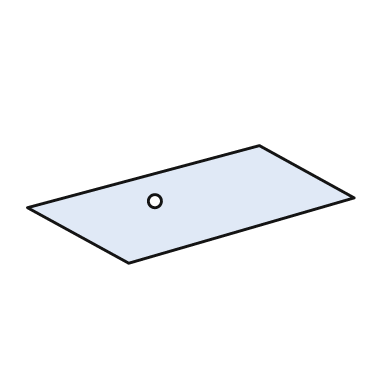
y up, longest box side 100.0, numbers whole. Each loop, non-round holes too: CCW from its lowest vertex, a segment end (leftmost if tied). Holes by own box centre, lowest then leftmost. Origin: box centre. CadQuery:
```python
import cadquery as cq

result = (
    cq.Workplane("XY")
    .moveTo(-19.0, -18.0)
    .lineTo(50.0, 2.0)
    .lineTo(21.0, 18.0)
    .lineTo(-50.0, -1.0)
    .close()
    .moveTo(-11.0, 1.0)
    .circle(2.0)
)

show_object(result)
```